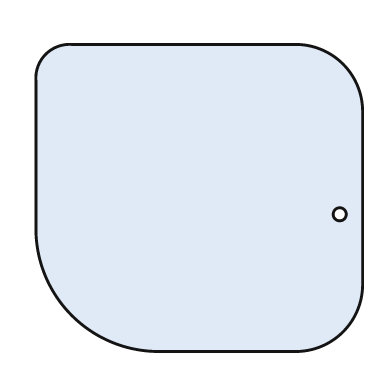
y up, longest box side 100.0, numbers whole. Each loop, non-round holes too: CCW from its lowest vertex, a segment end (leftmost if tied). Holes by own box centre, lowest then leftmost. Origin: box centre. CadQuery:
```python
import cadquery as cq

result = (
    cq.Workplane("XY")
    .moveTo(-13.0, -47.0)
    .lineTo(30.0, -47.0)
    .threePointArc((44.0, -41.0), (50.0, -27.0))
    .lineTo(50.0, 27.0)
    .threePointArc((44.0, 41.0), (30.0, 47.0))
    .lineTo(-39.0, 47.0)
    .threePointArc((-47.0, 44.0), (-50.0, 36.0))
    .lineTo(-50.0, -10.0)
    .threePointArc((-39.0, -36.0), (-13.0, -47.0))
    .close()
    .moveTo(43.0, -5.0)
    .circle(2.0)
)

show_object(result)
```